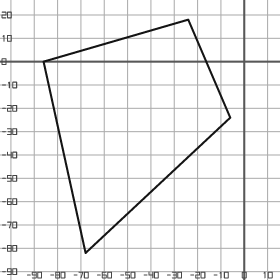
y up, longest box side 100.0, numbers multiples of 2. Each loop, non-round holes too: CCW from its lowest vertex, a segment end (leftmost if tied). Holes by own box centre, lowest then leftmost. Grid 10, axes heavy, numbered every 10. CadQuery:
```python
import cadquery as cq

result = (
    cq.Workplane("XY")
    .moveTo(-68.0, -82.0)
    .lineTo(-6.0, -24.0)
    .lineTo(-24.0, 18.0)
    .lineTo(-86.0, 0.0)
    .close()
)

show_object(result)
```